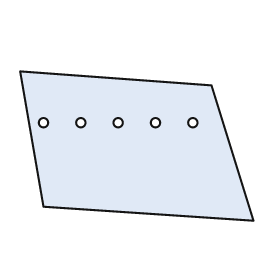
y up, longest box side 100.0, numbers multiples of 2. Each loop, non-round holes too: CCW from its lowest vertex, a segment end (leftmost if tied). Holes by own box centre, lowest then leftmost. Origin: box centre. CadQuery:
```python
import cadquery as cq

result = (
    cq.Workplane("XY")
    .moveTo(50.0, -32.0)
    .lineTo(32.0, 26.0)
    .lineTo(-50.0, 32.0)
    .lineTo(-40.0, -26.0)
    .close()
    .moveTo(-40.0, 10.0)
    .circle(2.0)
    .moveTo(-24.0, 10.0)
    .circle(2.0)
    .moveTo(-8.0, 10.0)
    .circle(2.0)
    .moveTo(8.0, 10.0)
    .circle(2.0)
    .moveTo(24.0, 10.0)
    .circle(2.0)
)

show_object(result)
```